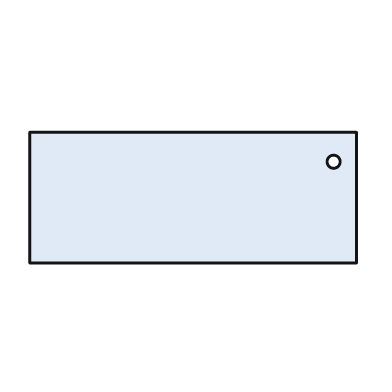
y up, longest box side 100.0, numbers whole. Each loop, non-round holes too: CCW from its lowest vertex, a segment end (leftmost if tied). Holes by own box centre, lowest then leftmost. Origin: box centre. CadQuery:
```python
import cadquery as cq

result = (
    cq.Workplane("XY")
    .moveTo(-50.0, -20.0)
    .lineTo(50.0, -20.0)
    .lineTo(50.0, 20.0)
    .lineTo(-50.0, 20.0)
    .close()
    .moveTo(43.0, 11.0)
    .circle(2.0)
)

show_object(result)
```